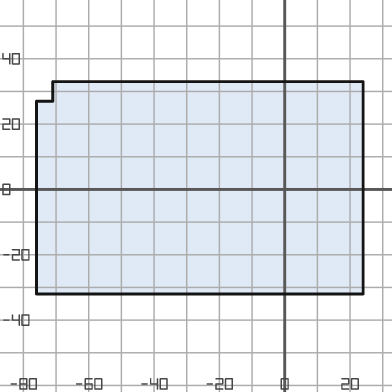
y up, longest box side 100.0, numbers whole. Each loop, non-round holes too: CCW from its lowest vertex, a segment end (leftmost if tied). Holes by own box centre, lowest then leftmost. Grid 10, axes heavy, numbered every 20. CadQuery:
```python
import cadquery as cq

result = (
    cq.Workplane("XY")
    .moveTo(-76.0, -32.0)
    .lineTo(24.0, -32.0)
    .lineTo(24.0, 33.0)
    .lineTo(-71.0, 33.0)
    .lineTo(-71.0, 27.0)
    .lineTo(-76.0, 27.0)
    .close()
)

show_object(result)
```